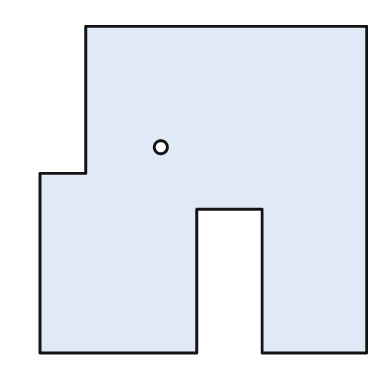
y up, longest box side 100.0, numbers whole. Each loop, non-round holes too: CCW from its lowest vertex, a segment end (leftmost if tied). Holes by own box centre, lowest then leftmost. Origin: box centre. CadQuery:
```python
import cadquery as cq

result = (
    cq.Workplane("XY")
    .moveTo(-50.0, -50.0)
    .lineTo(-2.0, -50.0)
    .lineTo(-2.0, -6.0)
    .lineTo(18.0, -6.0)
    .lineTo(18.0, -50.0)
    .lineTo(50.0, -50.0)
    .lineTo(50.0, 50.0)
    .lineTo(-36.0, 50.0)
    .lineTo(-36.0, 5.0)
    .lineTo(-50.0, 5.0)
    .close()
    .moveTo(-13.0, 13.0)
    .circle(2.0)
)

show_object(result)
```